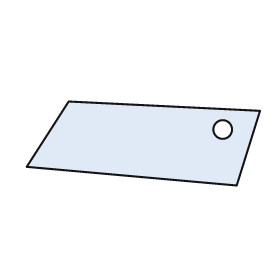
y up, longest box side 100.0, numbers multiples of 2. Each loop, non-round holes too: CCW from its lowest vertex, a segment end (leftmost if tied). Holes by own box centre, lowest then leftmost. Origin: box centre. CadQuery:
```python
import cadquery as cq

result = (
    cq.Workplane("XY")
    .moveTo(40.0, -18.0)
    .lineTo(50.0, 14.0)
    .lineTo(-32.0, 18.0)
    .lineTo(-50.0, -10.0)
    .close()
    .moveTo(34.0, 6.0)
    .circle(4.0)
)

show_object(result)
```